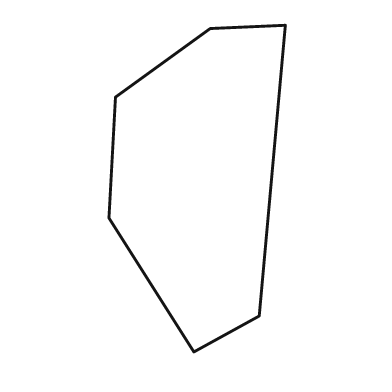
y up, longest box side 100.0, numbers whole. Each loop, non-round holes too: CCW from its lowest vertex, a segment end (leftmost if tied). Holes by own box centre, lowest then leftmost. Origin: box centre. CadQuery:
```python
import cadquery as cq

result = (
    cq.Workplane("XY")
    .moveTo(-1.0, -50.0)
    .lineTo(19.0, -39.0)
    .lineTo(27.0, 50.0)
    .lineTo(4.0, 49.0)
    .lineTo(-25.0, 28.0)
    .lineTo(-27.0, -9.0)
    .close()
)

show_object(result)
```